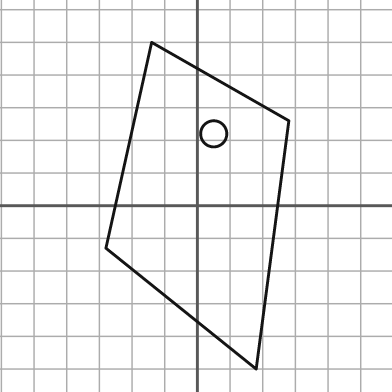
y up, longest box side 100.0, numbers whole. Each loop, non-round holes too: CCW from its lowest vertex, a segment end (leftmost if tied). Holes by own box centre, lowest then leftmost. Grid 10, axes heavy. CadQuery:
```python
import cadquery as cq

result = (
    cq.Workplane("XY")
    .moveTo(18.0, -50.0)
    .lineTo(28.0, 26.0)
    .lineTo(-14.0, 50.0)
    .lineTo(-28.0, -13.0)
    .close()
    .moveTo(5.0, 22.0)
    .circle(4.0)
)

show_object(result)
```